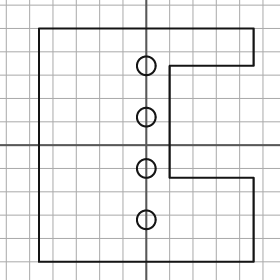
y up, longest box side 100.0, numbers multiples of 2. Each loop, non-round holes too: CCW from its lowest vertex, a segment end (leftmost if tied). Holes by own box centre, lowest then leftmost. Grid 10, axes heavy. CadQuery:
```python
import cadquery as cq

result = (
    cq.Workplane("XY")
    .moveTo(-46.0, -50.0)
    .lineTo(46.0, -50.0)
    .lineTo(46.0, -14.0)
    .lineTo(10.0, -14.0)
    .lineTo(10.0, 34.0)
    .lineTo(46.0, 34.0)
    .lineTo(46.0, 50.0)
    .lineTo(-46.0, 50.0)
    .close()
    .moveTo(0.0, -32.0)
    .circle(4.0)
    .moveTo(0.0, -10.0)
    .circle(4.0)
    .moveTo(0.0, 12.0)
    .circle(4.0)
    .moveTo(0.0, 34.0)
    .circle(4.0)
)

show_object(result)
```